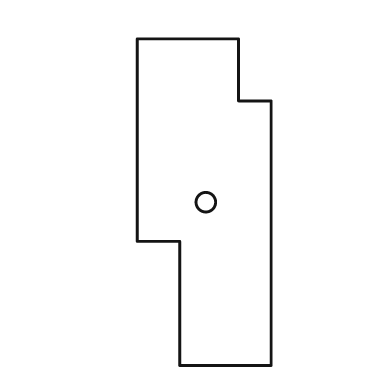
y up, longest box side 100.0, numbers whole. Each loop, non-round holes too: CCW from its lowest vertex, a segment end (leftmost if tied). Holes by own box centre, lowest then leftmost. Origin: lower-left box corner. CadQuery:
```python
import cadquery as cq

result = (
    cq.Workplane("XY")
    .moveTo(13.0, 0.0)
    .lineTo(41.0, 0.0)
    .lineTo(41.0, 81.0)
    .lineTo(31.0, 81.0)
    .lineTo(31.0, 100.0)
    .lineTo(0.0, 100.0)
    .lineTo(0.0, 38.0)
    .lineTo(13.0, 38.0)
    .close()
    .moveTo(21.0, 50.0)
    .circle(3.0)
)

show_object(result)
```